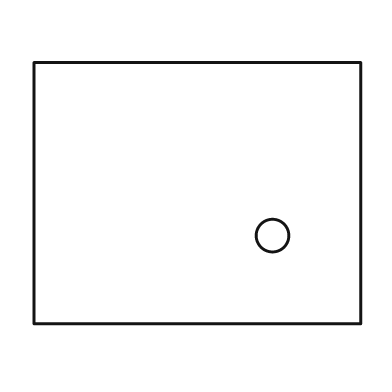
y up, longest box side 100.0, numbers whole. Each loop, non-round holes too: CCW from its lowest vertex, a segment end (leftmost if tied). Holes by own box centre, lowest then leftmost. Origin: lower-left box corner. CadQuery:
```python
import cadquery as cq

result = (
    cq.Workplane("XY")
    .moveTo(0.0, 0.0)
    .lineTo(100.0, 0.0)
    .lineTo(100.0, 80.0)
    .lineTo(0.0, 80.0)
    .close()
    .moveTo(73.0, 27.0)
    .circle(5.0)
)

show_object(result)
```